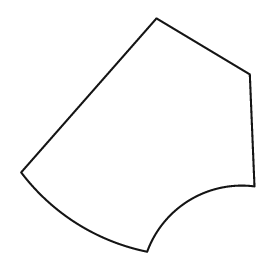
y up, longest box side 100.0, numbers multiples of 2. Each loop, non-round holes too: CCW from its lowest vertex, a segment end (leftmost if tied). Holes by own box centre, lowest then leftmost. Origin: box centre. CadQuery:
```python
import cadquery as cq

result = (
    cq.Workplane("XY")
    .moveTo(4.0, -50.0)
    .threePointArc((22.0, -28.0), (50.0, -22.0))
    .lineTo(48.0, 26.0)
    .lineTo(8.0, 50.0)
    .lineTo(-50.0, -16.0)
    .threePointArc((-26.0, -38.0), (4.0, -50.0))
    .close()
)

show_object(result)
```